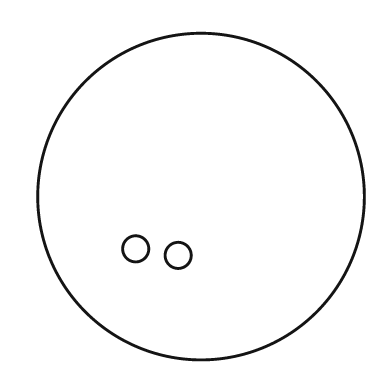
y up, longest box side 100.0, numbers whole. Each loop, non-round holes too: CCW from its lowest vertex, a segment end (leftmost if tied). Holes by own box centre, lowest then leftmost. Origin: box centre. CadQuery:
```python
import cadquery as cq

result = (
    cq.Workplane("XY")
    .moveTo(0.0, 0.0)
    .circle(50.0)
    .moveTo(-7.0, -18.0)
    .circle(4.0)
    .moveTo(-20.0, -16.0)
    .circle(4.0)
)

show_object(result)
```